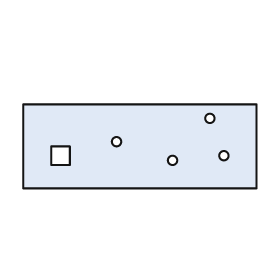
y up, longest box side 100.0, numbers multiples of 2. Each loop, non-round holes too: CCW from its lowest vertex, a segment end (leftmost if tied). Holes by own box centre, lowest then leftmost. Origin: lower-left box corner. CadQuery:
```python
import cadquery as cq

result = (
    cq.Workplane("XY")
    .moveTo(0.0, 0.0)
    .lineTo(100.0, 0.0)
    .lineTo(100.0, 36.0)
    .lineTo(0.0, 36.0)
    .close()
    .moveTo(64.0, 12.0)
    .circle(2.0)
    .moveTo(12.0, 10.0)
    .lineTo(20.0, 10.0)
    .lineTo(20.0, 18.0)
    .lineTo(12.0, 18.0)
    .close()
    .moveTo(86.0, 14.0)
    .circle(2.0)
    .moveTo(40.0, 20.0)
    .circle(2.0)
    .moveTo(80.0, 30.0)
    .circle(2.0)
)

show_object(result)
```